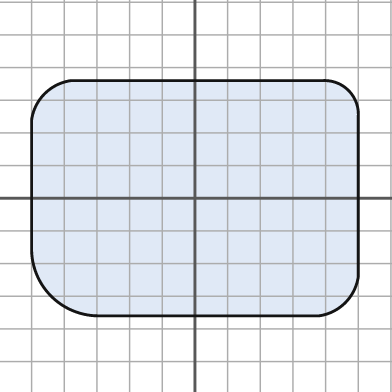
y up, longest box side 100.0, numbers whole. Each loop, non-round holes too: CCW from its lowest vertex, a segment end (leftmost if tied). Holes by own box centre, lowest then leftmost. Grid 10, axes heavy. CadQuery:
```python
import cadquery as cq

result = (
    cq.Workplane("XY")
    .moveTo(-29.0, -36.0)
    .lineTo(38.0, -36.0)
    .threePointArc((46.0, -32.0), (50.0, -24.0))
    .lineTo(50.0, 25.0)
    .threePointArc((47.0, 33.0), (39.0, 36.0))
    .lineTo(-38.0, 36.0)
    .threePointArc((-46.0, 32.0), (-50.0, 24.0))
    .lineTo(-50.0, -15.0)
    .threePointArc((-44.0, -30.0), (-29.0, -36.0))
    .close()
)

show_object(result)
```